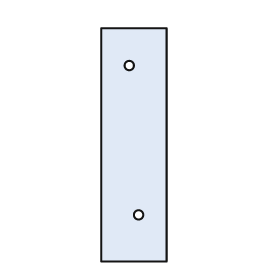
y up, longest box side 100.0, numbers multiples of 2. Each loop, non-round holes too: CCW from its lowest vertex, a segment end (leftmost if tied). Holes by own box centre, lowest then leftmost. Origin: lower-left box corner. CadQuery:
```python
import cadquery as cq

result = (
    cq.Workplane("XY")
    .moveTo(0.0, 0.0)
    .lineTo(28.0, 0.0)
    .lineTo(28.0, 100.0)
    .lineTo(0.0, 100.0)
    .close()
    .moveTo(16.0, 20.0)
    .circle(2.0)
    .moveTo(12.0, 84.0)
    .circle(2.0)
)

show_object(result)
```